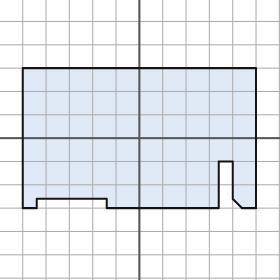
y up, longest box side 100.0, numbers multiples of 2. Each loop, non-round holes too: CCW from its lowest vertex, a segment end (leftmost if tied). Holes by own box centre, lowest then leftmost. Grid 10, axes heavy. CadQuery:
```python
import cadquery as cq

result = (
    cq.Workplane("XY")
    .moveTo(-50.0, -30.0)
    .lineTo(-44.0, -30.0)
    .lineTo(-44.0, -26.0)
    .lineTo(-14.0, -26.0)
    .lineTo(-14.0, -30.0)
    .lineTo(34.0, -30.0)
    .lineTo(34.0, -10.0)
    .lineTo(40.0, -10.0)
    .lineTo(40.0, -26.0)
    .lineTo(44.0, -30.0)
    .lineTo(50.0, -30.0)
    .lineTo(50.0, 30.0)
    .lineTo(-50.0, 30.0)
    .close()
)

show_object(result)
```